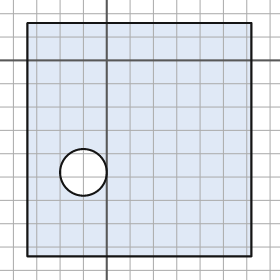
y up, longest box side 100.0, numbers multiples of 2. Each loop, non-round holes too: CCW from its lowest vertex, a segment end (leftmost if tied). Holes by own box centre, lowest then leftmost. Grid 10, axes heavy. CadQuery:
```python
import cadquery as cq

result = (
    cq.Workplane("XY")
    .moveTo(-34.0, -84.0)
    .lineTo(62.0, -84.0)
    .lineTo(62.0, 16.0)
    .lineTo(-34.0, 16.0)
    .close()
    .moveTo(-10.0, -48.0)
    .circle(10.0)
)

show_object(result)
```